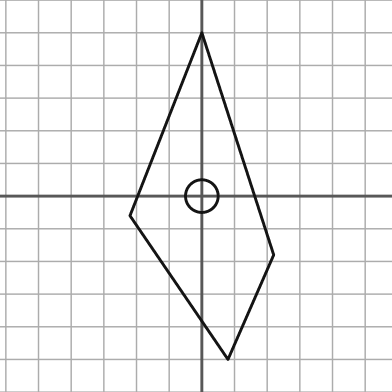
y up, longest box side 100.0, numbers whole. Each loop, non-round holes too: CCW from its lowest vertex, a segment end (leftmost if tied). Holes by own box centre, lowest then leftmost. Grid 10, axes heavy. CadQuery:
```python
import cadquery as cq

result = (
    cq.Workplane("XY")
    .moveTo(8.0, -50.0)
    .lineTo(22.0, -18.0)
    .lineTo(0.0, 50.0)
    .lineTo(-22.0, -6.0)
    .close()
    .moveTo(0.0, 0.0)
    .circle(5.0)
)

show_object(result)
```